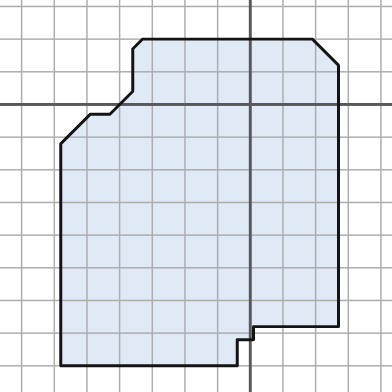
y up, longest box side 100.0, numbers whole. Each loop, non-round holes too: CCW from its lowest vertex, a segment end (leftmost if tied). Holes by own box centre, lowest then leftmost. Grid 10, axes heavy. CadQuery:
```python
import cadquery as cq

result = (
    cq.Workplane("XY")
    .moveTo(-58.0, -80.0)
    .lineTo(-4.0, -80.0)
    .lineTo(-4.0, -72.0)
    .lineTo(1.0, -72.0)
    .lineTo(1.0, -68.0)
    .lineTo(27.0, -68.0)
    .lineTo(27.0, 12.0)
    .lineTo(19.0, 20.0)
    .lineTo(-33.0, 20.0)
    .lineTo(-36.0, 17.0)
    .lineTo(-36.0, 4.0)
    .lineTo(-43.0, -3.0)
    .lineTo(-49.0, -3.0)
    .lineTo(-58.0, -12.0)
    .close()
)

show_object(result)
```